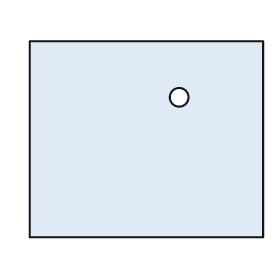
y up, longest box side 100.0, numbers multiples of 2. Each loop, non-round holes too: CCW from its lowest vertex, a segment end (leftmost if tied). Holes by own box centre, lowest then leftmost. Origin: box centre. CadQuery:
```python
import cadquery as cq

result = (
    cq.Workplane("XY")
    .moveTo(-50.0, -42.0)
    .lineTo(50.0, -42.0)
    .lineTo(50.0, 42.0)
    .lineTo(-50.0, 42.0)
    .close()
    .moveTo(14.0, 18.0)
    .circle(4.0)
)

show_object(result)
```